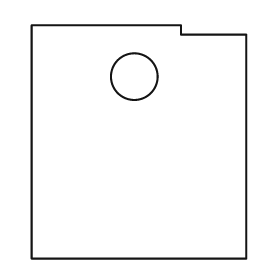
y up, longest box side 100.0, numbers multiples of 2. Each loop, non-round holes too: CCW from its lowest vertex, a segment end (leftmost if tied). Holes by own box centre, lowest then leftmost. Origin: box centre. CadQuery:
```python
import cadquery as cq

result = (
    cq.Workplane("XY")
    .moveTo(-46.0, -50.0)
    .lineTo(46.0, -50.0)
    .lineTo(46.0, 46.0)
    .lineTo(18.0, 46.0)
    .lineTo(18.0, 50.0)
    .lineTo(-46.0, 50.0)
    .close()
    .moveTo(-2.0, 28.0)
    .circle(10.0)
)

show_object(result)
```